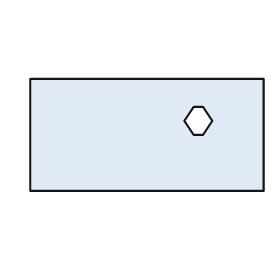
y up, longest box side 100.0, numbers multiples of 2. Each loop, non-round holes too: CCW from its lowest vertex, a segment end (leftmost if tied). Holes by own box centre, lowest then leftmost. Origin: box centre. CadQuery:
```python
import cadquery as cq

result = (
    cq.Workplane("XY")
    .moveTo(-50.0, -24.0)
    .lineTo(50.0, -24.0)
    .lineTo(50.0, 24.0)
    .lineTo(-50.0, 24.0)
    .close()
    .moveTo(20.0, 0.0)
    .lineTo(24.0, 0.0)
    .lineTo(28.0, 6.0)
    .lineTo(24.0, 12.0)
    .lineTo(20.0, 12.0)
    .lineTo(16.0, 6.0)
    .close()
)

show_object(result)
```